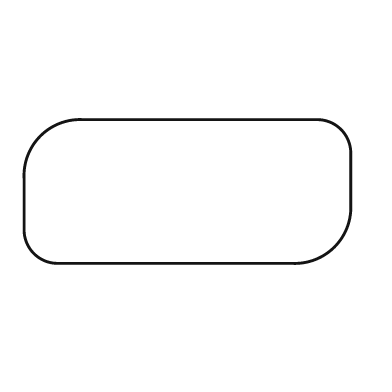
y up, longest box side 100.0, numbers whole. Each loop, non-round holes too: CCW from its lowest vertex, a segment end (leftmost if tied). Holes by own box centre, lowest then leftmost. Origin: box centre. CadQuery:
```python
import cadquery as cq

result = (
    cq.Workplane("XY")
    .moveTo(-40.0, -22.0)
    .lineTo(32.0, -22.0)
    .threePointArc((45.0, -17.0), (50.0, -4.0))
    .lineTo(50.0, 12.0)
    .threePointArc((47.0, 19.0), (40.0, 22.0))
    .lineTo(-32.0, 22.0)
    .threePointArc((-45.0, 17.0), (-50.0, 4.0))
    .lineTo(-50.0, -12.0)
    .threePointArc((-47.0, -19.0), (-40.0, -22.0))
    .close()
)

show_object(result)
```